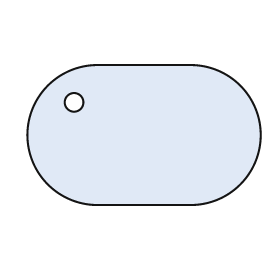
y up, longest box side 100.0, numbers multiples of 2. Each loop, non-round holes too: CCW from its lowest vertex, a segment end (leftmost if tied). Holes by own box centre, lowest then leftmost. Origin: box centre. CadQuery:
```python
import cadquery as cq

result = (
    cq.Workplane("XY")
    .moveTo(-20.0, -30.0)
    .lineTo(20.0, -30.0)
    .threePointArc((50.0, 0.0), (20.0, 30.0))
    .lineTo(-20.0, 30.0)
    .threePointArc((-50.0, 0.0), (-20.0, -30.0))
    .close()
    .moveTo(-30.0, 14.0)
    .circle(4.0)
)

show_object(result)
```